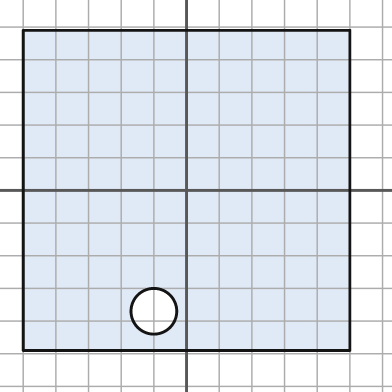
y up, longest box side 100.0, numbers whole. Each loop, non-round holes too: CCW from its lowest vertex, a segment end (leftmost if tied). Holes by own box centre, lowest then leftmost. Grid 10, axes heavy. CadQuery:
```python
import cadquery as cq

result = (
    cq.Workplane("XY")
    .moveTo(-50.0, -49.0)
    .lineTo(50.0, -49.0)
    .lineTo(50.0, 49.0)
    .lineTo(-50.0, 49.0)
    .close()
    .moveTo(-10.0, -37.0)
    .circle(7.0)
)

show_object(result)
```